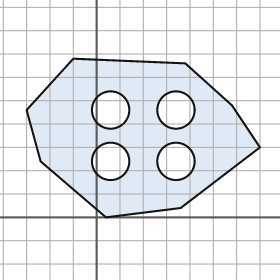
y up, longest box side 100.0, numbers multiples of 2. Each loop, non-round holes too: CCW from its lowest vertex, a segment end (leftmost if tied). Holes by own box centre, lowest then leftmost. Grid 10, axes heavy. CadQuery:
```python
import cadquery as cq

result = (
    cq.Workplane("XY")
    .moveTo(4.0, 0.0)
    .lineTo(36.0, 4.0)
    .lineTo(70.0, 30.0)
    .lineTo(58.0, 48.0)
    .lineTo(38.0, 66.0)
    .lineTo(-10.0, 68.0)
    .lineTo(-30.0, 46.0)
    .lineTo(-24.0, 24.0)
    .close()
    .moveTo(6.0, 24.0)
    .circle(8.0)
    .moveTo(34.0, 24.0)
    .circle(8.0)
    .moveTo(6.0, 46.0)
    .circle(8.0)
    .moveTo(34.0, 46.0)
    .circle(8.0)
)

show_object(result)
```